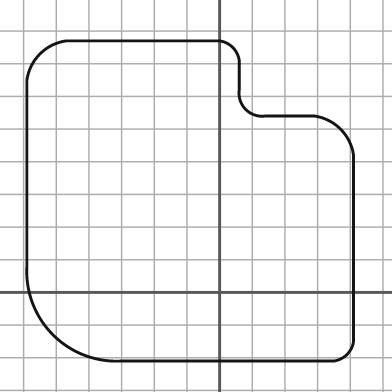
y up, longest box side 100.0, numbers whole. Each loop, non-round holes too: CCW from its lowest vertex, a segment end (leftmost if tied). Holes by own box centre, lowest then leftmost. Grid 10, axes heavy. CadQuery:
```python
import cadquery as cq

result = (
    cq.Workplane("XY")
    .moveTo(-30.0, -21.0)
    .lineTo(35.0, -21.0)
    .threePointArc((39.0, -19.0), (41.0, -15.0))
    .lineTo(41.0, 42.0)
    .threePointArc((37.0, 50.0), (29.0, 54.0))
    .lineTo(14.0, 54.0)
    .threePointArc((8.0, 56.0), (6.0, 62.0))
    .lineTo(6.0, 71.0)
    .threePointArc((4.0, 75.0), (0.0, 77.0))
    .lineTo(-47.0, 77.0)
    .threePointArc((-55.0, 73.0), (-59.0, 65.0))
    .lineTo(-59.0, 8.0)
    .threePointArc((-51.0, -13.0), (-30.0, -21.0))
    .close()
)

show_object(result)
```